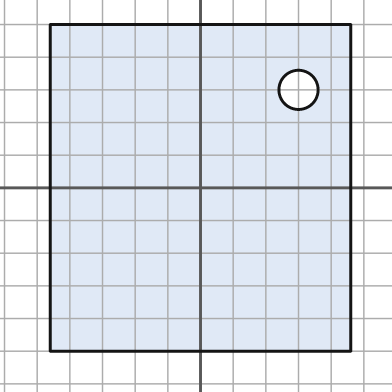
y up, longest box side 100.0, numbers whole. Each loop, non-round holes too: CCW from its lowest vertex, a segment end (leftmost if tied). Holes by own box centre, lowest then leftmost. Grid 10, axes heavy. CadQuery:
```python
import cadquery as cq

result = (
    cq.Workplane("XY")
    .moveTo(-46.0, -50.0)
    .lineTo(46.0, -50.0)
    .lineTo(46.0, 50.0)
    .lineTo(-46.0, 50.0)
    .close()
    .moveTo(30.0, 30.0)
    .circle(6.0)
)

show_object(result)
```